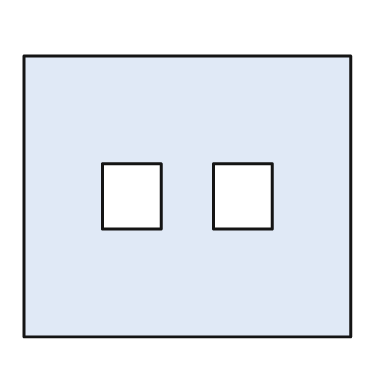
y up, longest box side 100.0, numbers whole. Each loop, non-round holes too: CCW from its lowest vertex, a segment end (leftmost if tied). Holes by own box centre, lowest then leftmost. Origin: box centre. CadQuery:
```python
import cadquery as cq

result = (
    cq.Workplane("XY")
    .moveTo(-50.0, -43.0)
    .lineTo(50.0, -43.0)
    .lineTo(50.0, 43.0)
    .lineTo(-50.0, 43.0)
    .close()
    .moveTo(-26.0, -10.0)
    .lineTo(-8.0, -10.0)
    .lineTo(-8.0, 10.0)
    .lineTo(-26.0, 10.0)
    .close()
    .moveTo(8.0, -10.0)
    .lineTo(26.0, -10.0)
    .lineTo(26.0, 10.0)
    .lineTo(8.0, 10.0)
    .close()
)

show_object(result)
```